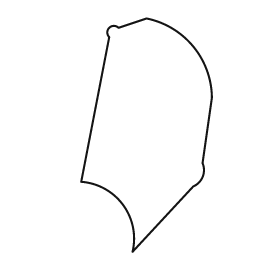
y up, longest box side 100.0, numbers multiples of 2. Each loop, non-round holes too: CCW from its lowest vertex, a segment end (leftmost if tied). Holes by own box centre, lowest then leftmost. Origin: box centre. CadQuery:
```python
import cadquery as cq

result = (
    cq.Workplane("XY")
    .moveTo(-6.0, -50.0)
    .lineTo(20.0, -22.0)
    .threePointArc((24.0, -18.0), (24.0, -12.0))
    .lineTo(28.0, 16.0)
    .threePointArc((20.0, 38.0), (0.0, 50.0))
    .lineTo(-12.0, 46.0)
    .threePointArc((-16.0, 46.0), (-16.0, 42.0))
    .lineTo(-28.0, -20.0)
    .threePointArc((-10.0, -30.0), (-6.0, -50.0))
    .close()
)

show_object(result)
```